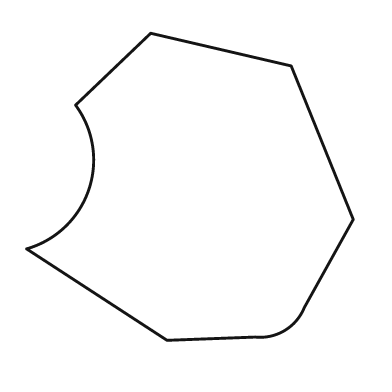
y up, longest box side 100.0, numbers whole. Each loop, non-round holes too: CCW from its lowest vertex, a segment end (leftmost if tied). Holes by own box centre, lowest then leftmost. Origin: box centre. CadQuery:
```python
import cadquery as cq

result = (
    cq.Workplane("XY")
    .moveTo(-7.0, -47.0)
    .lineTo(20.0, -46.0)
    .threePointArc((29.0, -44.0), (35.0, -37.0))
    .lineTo(50.0, -10.0)
    .lineTo(31.0, 37.0)
    .lineTo(-12.0, 47.0)
    .lineTo(-35.0, 25.0)
    .threePointArc((-31.0, -1.0), (-50.0, -19.0))
    .close()
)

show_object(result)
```